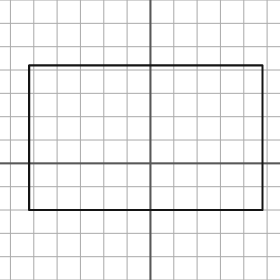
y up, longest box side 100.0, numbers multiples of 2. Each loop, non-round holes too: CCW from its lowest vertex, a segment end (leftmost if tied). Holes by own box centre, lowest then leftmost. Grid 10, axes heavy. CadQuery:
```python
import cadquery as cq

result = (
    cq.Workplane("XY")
    .moveTo(-52.0, -20.0)
    .lineTo(48.0, -20.0)
    .lineTo(48.0, 42.0)
    .lineTo(-52.0, 42.0)
    .close()
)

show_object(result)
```